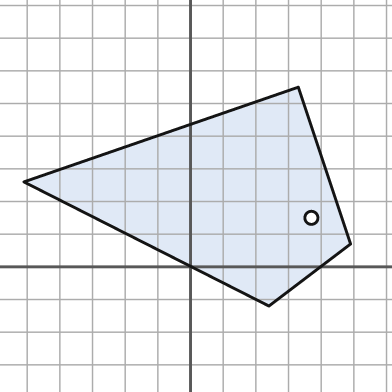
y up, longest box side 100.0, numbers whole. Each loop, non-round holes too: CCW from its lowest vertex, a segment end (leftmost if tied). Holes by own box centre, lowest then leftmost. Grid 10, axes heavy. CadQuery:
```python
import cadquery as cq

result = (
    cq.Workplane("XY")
    .moveTo(24.0, -12.0)
    .lineTo(49.0, 7.0)
    .lineTo(33.0, 55.0)
    .lineTo(-51.0, 26.0)
    .close()
    .moveTo(37.0, 15.0)
    .circle(2.0)
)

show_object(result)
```